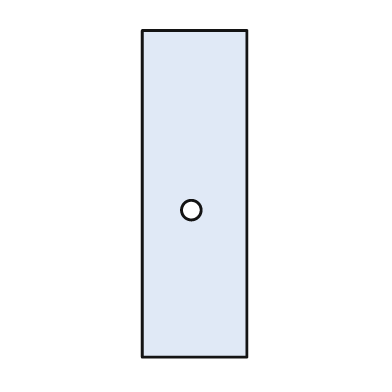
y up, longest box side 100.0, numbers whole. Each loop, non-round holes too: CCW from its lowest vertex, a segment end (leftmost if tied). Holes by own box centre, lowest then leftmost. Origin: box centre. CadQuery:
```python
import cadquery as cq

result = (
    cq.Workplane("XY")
    .moveTo(-16.0, -50.0)
    .lineTo(16.0, -50.0)
    .lineTo(16.0, 50.0)
    .lineTo(-16.0, 50.0)
    .close()
    .moveTo(-1.0, -5.0)
    .circle(3.0)
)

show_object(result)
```